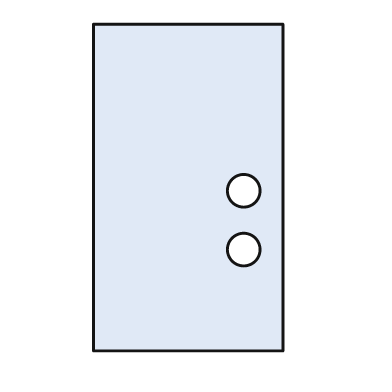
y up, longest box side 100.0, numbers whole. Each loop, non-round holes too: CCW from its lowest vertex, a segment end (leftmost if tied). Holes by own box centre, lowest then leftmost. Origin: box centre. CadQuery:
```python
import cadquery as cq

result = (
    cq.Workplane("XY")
    .moveTo(-29.0, -50.0)
    .lineTo(29.0, -50.0)
    .lineTo(29.0, 50.0)
    .lineTo(-29.0, 50.0)
    .close()
    .moveTo(17.0, -19.0)
    .circle(5.0)
    .moveTo(17.0, -1.0)
    .circle(5.0)
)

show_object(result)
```